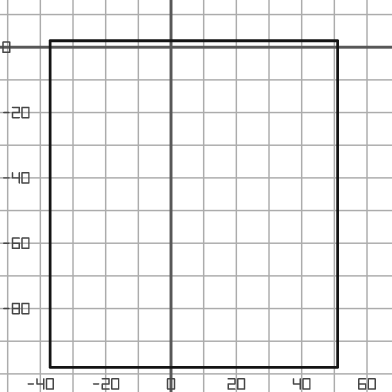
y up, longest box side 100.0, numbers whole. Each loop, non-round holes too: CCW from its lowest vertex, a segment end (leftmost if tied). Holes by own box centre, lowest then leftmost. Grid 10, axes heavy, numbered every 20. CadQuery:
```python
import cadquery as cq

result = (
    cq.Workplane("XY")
    .moveTo(-37.0, -98.0)
    .lineTo(51.0, -98.0)
    .lineTo(51.0, 2.0)
    .lineTo(-37.0, 2.0)
    .close()
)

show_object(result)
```